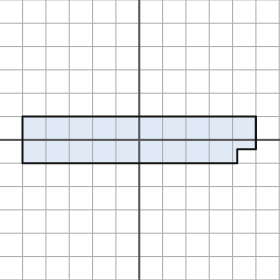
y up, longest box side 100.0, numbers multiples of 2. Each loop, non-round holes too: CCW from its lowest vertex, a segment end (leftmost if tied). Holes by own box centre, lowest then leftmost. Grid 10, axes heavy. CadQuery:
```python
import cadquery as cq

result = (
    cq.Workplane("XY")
    .moveTo(-50.0, -10.0)
    .lineTo(42.0, -10.0)
    .lineTo(42.0, -4.0)
    .lineTo(50.0, -4.0)
    .lineTo(50.0, 10.0)
    .lineTo(-50.0, 10.0)
    .close()
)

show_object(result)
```